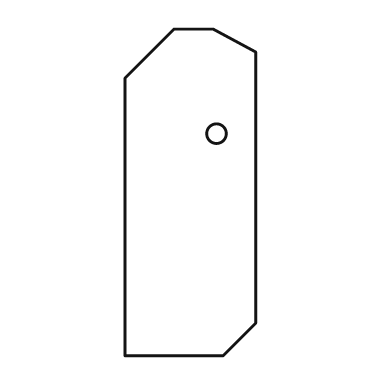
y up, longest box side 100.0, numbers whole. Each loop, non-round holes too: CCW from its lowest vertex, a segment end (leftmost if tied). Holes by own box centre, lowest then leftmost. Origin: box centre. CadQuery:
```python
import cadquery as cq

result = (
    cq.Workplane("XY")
    .moveTo(-20.0, -50.0)
    .lineTo(10.0, -50.0)
    .lineTo(20.0, -40.0)
    .lineTo(20.0, 43.0)
    .lineTo(7.0, 50.0)
    .lineTo(-5.0, 50.0)
    .lineTo(-20.0, 35.0)
    .close()
    .moveTo(8.0, 18.0)
    .circle(3.0)
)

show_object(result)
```